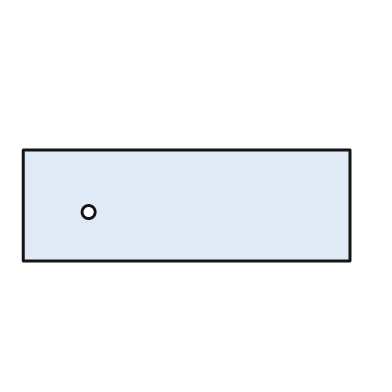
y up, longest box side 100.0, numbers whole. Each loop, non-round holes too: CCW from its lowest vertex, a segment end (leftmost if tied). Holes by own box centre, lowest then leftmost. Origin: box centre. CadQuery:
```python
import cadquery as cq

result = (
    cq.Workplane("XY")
    .moveTo(-50.0, -17.0)
    .lineTo(50.0, -17.0)
    .lineTo(50.0, 17.0)
    .lineTo(-50.0, 17.0)
    .close()
    .moveTo(-30.0, -2.0)
    .circle(2.0)
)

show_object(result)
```